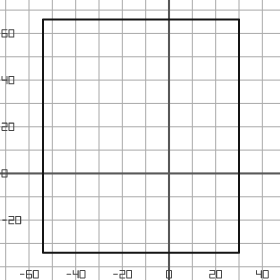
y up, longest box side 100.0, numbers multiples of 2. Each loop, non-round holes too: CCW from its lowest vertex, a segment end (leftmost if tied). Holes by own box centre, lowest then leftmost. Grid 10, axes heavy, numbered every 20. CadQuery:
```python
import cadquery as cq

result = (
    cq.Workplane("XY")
    .moveTo(-54.0, -34.0)
    .lineTo(30.0, -34.0)
    .lineTo(30.0, 66.0)
    .lineTo(-54.0, 66.0)
    .close()
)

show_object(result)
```